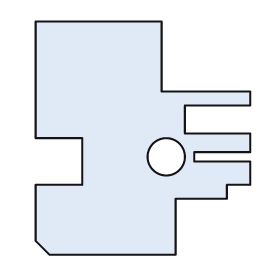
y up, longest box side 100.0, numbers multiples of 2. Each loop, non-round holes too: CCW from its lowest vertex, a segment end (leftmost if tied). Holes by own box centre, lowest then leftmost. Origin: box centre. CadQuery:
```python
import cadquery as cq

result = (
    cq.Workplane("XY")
    .moveTo(-40.0, -50.0)
    .lineTo(14.0, -50.0)
    .lineTo(14.0, -26.0)
    .lineTo(36.0, -26.0)
    .lineTo(36.0, -20.0)
    .lineTo(46.0, -20.0)
    .lineTo(46.0, -10.0)
    .lineTo(22.0, -10.0)
    .lineTo(22.0, -6.0)
    .lineTo(46.0, -6.0)
    .lineTo(46.0, 2.0)
    .lineTo(18.0, 2.0)
    .lineTo(18.0, 14.0)
    .lineTo(46.0, 14.0)
    .lineTo(46.0, 20.0)
    .lineTo(8.0, 20.0)
    .lineTo(8.0, 50.0)
    .lineTo(-46.0, 50.0)
    .lineTo(-46.0, 0.0)
    .lineTo(-26.0, 0.0)
    .lineTo(-26.0, -20.0)
    .lineTo(-46.0, -20.0)
    .lineTo(-46.0, -44.0)
    .close()
    .moveTo(10.0, -8.0)
    .circle(8.0)
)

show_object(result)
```